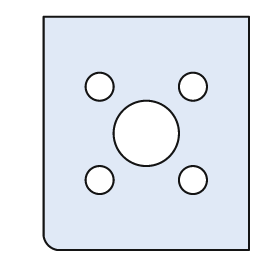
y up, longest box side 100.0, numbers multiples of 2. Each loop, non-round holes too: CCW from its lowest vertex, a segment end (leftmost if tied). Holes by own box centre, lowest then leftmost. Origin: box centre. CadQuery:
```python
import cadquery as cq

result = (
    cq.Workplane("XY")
    .moveTo(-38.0, -50.0)
    .lineTo(44.0, -50.0)
    .lineTo(44.0, 50.0)
    .lineTo(-44.0, 50.0)
    .lineTo(-44.0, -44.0)
    .threePointArc((-42.0, -48.0), (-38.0, -50.0))
    .close()
    .moveTo(-20.0, -20.0)
    .circle(6.0)
    .moveTo(20.0, -20.0)
    .circle(6.0)
    .moveTo(0.0, 0.0)
    .circle(14.0)
    .moveTo(-20.0, 20.0)
    .circle(6.0)
    .moveTo(20.0, 20.0)
    .circle(6.0)
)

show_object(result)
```